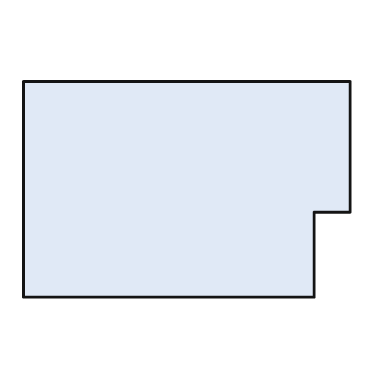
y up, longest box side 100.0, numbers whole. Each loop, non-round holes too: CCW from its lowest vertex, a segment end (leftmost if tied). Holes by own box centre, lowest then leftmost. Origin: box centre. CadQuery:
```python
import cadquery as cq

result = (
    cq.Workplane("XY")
    .moveTo(-50.0, -33.0)
    .lineTo(39.0, -33.0)
    .lineTo(39.0, -7.0)
    .lineTo(50.0, -7.0)
    .lineTo(50.0, 33.0)
    .lineTo(-50.0, 33.0)
    .close()
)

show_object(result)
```